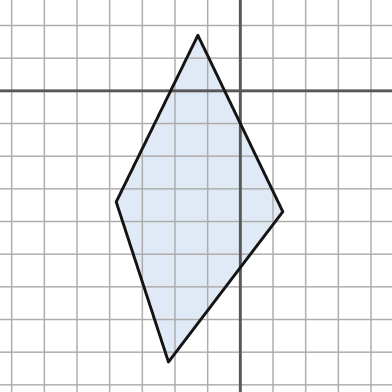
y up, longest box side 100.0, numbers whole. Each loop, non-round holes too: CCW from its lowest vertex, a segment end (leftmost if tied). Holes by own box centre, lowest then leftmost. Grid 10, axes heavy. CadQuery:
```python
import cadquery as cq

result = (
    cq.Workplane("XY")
    .moveTo(-22.0, -83.0)
    .lineTo(13.0, -37.0)
    .lineTo(-13.0, 17.0)
    .lineTo(-38.0, -34.0)
    .close()
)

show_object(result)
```